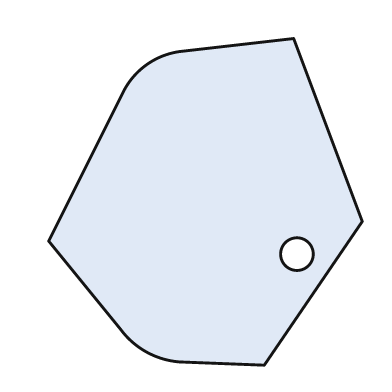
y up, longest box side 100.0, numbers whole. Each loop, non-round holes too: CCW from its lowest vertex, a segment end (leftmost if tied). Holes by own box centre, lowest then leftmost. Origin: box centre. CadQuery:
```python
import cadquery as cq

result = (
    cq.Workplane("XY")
    .moveTo(18.0, -50.0)
    .lineTo(48.0, -6.0)
    .lineTo(27.0, 50.0)
    .lineTo(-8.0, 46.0)
    .threePointArc((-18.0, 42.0), (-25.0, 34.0))
    .lineTo(-48.0, -12.0)
    .lineTo(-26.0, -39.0)
    .threePointArc((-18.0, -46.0), (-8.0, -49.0))
    .close()
    .moveTo(28.0, -16.0)
    .circle(5.0)
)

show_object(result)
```